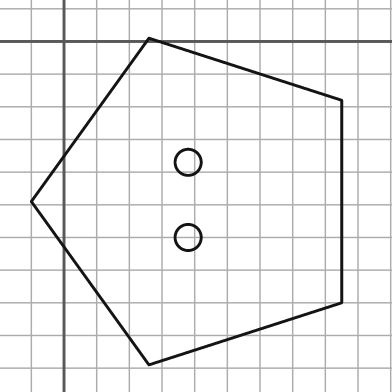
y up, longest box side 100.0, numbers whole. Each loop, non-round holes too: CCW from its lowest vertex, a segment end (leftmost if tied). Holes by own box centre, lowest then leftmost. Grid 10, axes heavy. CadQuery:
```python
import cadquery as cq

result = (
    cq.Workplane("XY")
    .moveTo(26.0, -99.0)
    .lineTo(85.0, -80.0)
    .lineTo(85.0, -18.0)
    .lineTo(26.0, 1.0)
    .lineTo(-10.0, -49.0)
    .close()
    .moveTo(38.0, -60.0)
    .circle(4.0)
    .moveTo(38.0, -37.0)
    .circle(4.0)
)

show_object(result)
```